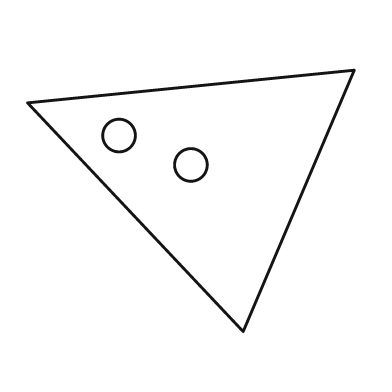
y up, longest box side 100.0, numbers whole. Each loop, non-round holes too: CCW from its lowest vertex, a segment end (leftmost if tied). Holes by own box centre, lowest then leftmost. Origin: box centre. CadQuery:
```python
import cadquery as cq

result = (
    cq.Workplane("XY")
    .moveTo(16.0, -40.0)
    .lineTo(50.0, 40.0)
    .lineTo(-50.0, 30.0)
    .close()
    .moveTo(0.0, 11.0)
    .circle(5.0)
    .moveTo(-22.0, 20.0)
    .circle(5.0)
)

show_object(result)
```